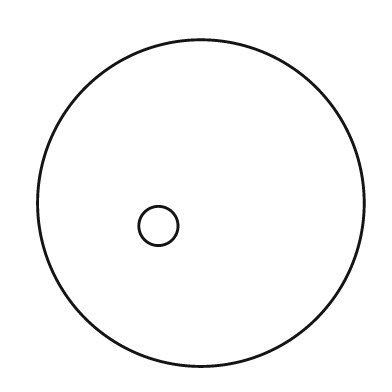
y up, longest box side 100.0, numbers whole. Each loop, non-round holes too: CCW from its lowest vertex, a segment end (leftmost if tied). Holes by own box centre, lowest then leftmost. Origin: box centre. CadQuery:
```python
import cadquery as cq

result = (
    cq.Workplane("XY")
    .moveTo(0.0, 0.0)
    .circle(50.0)
    .moveTo(-13.0, -7.0)
    .circle(6.0)
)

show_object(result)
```